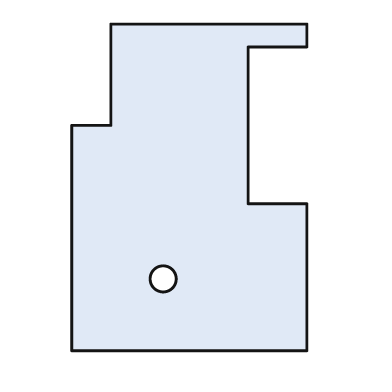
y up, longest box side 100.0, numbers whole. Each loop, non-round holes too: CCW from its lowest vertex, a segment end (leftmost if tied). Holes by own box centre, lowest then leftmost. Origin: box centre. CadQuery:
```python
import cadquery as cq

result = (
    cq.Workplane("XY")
    .moveTo(-36.0, -50.0)
    .lineTo(36.0, -50.0)
    .lineTo(36.0, -5.0)
    .lineTo(18.0, -5.0)
    .lineTo(18.0, 43.0)
    .lineTo(36.0, 43.0)
    .lineTo(36.0, 50.0)
    .lineTo(-24.0, 50.0)
    .lineTo(-24.0, 19.0)
    .lineTo(-36.0, 19.0)
    .close()
    .moveTo(-8.0, -28.0)
    .circle(4.0)
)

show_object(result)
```